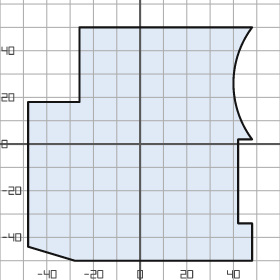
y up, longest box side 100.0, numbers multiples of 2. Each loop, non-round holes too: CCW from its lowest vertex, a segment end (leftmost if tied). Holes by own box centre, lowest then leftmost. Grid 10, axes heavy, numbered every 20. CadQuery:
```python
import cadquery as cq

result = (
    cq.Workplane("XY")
    .moveTo(-28.0, -50.0)
    .lineTo(48.0, -50.0)
    .lineTo(48.0, -34.0)
    .lineTo(42.0, -34.0)
    .lineTo(42.0, 2.0)
    .lineTo(48.0, 2.0)
    .threePointArc((40.0, 26.0), (48.0, 50.0))
    .lineTo(-26.0, 50.0)
    .lineTo(-26.0, 18.0)
    .lineTo(-48.0, 18.0)
    .lineTo(-48.0, -44.0)
    .close()
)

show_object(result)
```